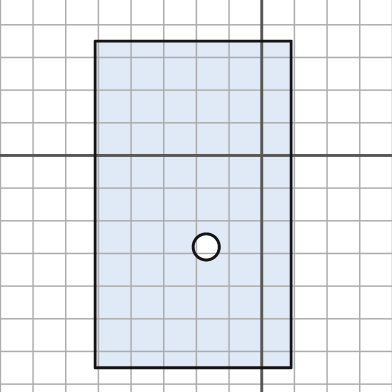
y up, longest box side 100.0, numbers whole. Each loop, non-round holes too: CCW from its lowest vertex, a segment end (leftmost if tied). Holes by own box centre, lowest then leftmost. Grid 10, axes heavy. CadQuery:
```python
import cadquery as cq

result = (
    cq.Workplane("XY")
    .moveTo(-51.0, -65.0)
    .lineTo(9.0, -65.0)
    .lineTo(9.0, 35.0)
    .lineTo(-51.0, 35.0)
    .close()
    .moveTo(-17.0, -28.0)
    .circle(4.0)
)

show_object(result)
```